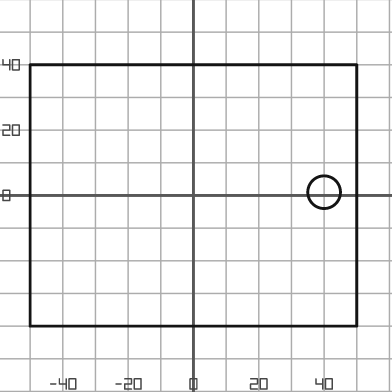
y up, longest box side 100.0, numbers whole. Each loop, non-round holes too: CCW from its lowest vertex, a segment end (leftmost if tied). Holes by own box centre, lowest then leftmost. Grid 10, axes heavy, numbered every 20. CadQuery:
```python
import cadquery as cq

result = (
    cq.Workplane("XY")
    .moveTo(-50.0, -40.0)
    .lineTo(50.0, -40.0)
    .lineTo(50.0, 40.0)
    .lineTo(-50.0, 40.0)
    .close()
    .moveTo(40.0, 1.0)
    .circle(5.0)
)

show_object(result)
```